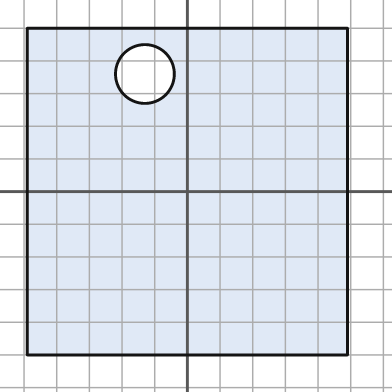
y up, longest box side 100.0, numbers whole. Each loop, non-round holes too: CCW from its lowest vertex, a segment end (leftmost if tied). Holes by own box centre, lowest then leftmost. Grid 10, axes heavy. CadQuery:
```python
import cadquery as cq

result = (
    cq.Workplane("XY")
    .moveTo(-49.0, -50.0)
    .lineTo(49.0, -50.0)
    .lineTo(49.0, 50.0)
    .lineTo(-49.0, 50.0)
    .close()
    .moveTo(-13.0, 36.0)
    .circle(9.0)
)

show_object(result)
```